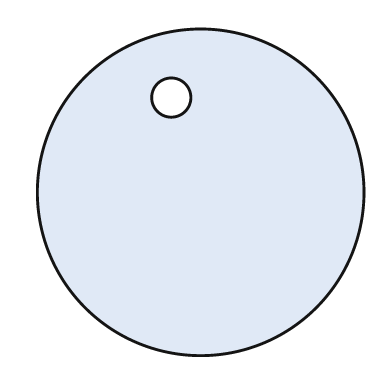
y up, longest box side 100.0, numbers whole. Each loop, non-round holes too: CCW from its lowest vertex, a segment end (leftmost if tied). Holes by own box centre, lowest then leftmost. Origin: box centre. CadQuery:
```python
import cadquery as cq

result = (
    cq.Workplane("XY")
    .moveTo(0.0, 0.0)
    .circle(50.0)
    .moveTo(-9.0, 29.0)
    .circle(6.0)
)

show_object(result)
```